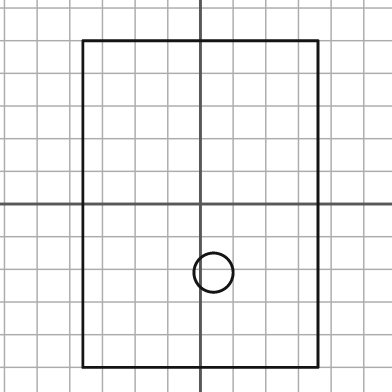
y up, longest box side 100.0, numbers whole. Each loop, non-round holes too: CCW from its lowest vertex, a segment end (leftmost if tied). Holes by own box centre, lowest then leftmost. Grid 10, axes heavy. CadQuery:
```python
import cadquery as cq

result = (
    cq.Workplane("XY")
    .moveTo(-36.0, -50.0)
    .lineTo(36.0, -50.0)
    .lineTo(36.0, 50.0)
    .lineTo(-36.0, 50.0)
    .close()
    .moveTo(4.0, -21.0)
    .circle(6.0)
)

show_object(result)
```